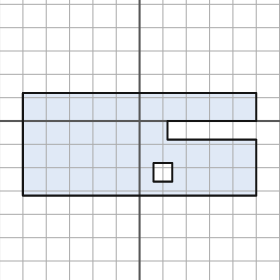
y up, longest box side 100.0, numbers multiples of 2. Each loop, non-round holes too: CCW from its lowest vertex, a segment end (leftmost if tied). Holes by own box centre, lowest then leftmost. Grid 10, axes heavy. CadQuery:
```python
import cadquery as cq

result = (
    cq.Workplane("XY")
    .moveTo(-50.0, -32.0)
    .lineTo(50.0, -32.0)
    .lineTo(50.0, -8.0)
    .lineTo(12.0, -8.0)
    .lineTo(12.0, 0.0)
    .lineTo(50.0, 0.0)
    .lineTo(50.0, 12.0)
    .lineTo(-50.0, 12.0)
    .close()
    .moveTo(6.0, -26.0)
    .lineTo(14.0, -26.0)
    .lineTo(14.0, -18.0)
    .lineTo(6.0, -18.0)
    .close()
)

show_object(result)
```